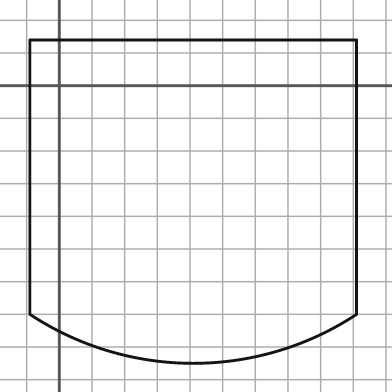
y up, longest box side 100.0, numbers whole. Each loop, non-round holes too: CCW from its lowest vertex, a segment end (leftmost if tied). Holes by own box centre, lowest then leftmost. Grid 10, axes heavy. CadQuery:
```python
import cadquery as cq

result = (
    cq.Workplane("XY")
    .moveTo(-9.0, -70.0)
    .threePointArc((41.0, -85.0), (91.0, -70.0))
    .lineTo(91.0, 14.0)
    .lineTo(-9.0, 14.0)
    .close()
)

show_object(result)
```